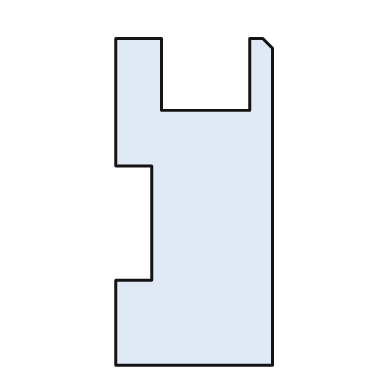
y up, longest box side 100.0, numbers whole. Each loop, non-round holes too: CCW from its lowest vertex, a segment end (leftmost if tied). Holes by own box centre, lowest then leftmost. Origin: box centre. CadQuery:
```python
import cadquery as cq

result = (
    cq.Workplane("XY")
    .moveTo(-24.0, -50.0)
    .lineTo(24.0, -50.0)
    .lineTo(24.0, 47.0)
    .lineTo(21.0, 50.0)
    .lineTo(17.0, 50.0)
    .lineTo(17.0, 28.0)
    .lineTo(-10.0, 28.0)
    .lineTo(-10.0, 50.0)
    .lineTo(-24.0, 50.0)
    .lineTo(-24.0, 11.0)
    .lineTo(-13.0, 11.0)
    .lineTo(-13.0, -24.0)
    .lineTo(-24.0, -24.0)
    .close()
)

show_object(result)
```